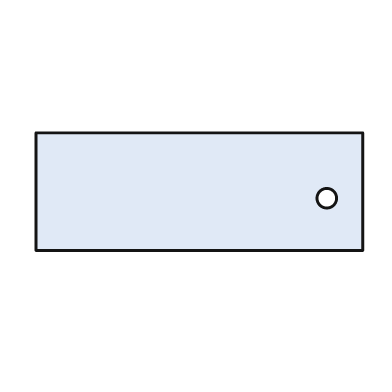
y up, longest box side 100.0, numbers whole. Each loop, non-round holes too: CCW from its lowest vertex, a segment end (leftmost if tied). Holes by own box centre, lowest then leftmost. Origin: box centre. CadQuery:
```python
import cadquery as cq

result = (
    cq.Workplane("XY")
    .moveTo(-50.0, -18.0)
    .lineTo(50.0, -18.0)
    .lineTo(50.0, 18.0)
    .lineTo(-50.0, 18.0)
    .close()
    .moveTo(39.0, -2.0)
    .circle(3.0)
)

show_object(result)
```